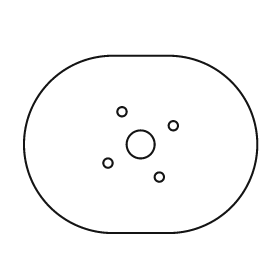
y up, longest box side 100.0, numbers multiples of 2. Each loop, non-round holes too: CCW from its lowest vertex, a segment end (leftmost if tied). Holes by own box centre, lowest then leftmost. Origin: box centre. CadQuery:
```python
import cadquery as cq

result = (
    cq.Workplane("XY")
    .moveTo(-12.0, -38.0)
    .lineTo(12.0, -38.0)
    .threePointArc((50.0, 0.0), (12.0, 38.0))
    .lineTo(-12.0, 38.0)
    .threePointArc((-50.0, 0.0), (-12.0, -38.0))
    .close()
    .moveTo(8.0, -14.0)
    .circle(2.0)
    .moveTo(-14.0, -8.0)
    .circle(2.0)
    .moveTo(0.0, 0.0)
    .circle(6.0)
    .moveTo(14.0, 8.0)
    .circle(2.0)
    .moveTo(-8.0, 14.0)
    .circle(2.0)
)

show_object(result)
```